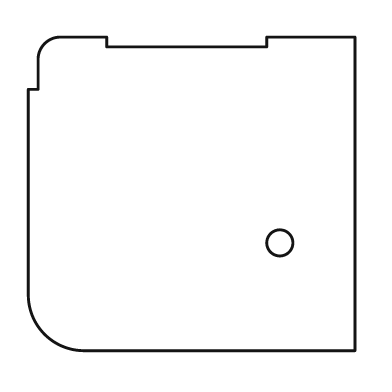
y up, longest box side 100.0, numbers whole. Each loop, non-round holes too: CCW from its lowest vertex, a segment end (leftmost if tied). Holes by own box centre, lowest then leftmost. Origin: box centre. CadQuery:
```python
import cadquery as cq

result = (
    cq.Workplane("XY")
    .moveTo(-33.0, -48.0)
    .lineTo(50.0, -48.0)
    .lineTo(50.0, 48.0)
    .lineTo(23.0, 48.0)
    .lineTo(23.0, 45.0)
    .lineTo(-26.0, 45.0)
    .lineTo(-26.0, 48.0)
    .lineTo(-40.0, 48.0)
    .threePointArc((-45.0, 46.0), (-47.0, 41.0))
    .lineTo(-47.0, 32.0)
    .lineTo(-50.0, 32.0)
    .lineTo(-50.0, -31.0)
    .threePointArc((-45.0, -43.0), (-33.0, -48.0))
    .close()
    .moveTo(27.0, -15.0)
    .circle(4.0)
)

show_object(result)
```